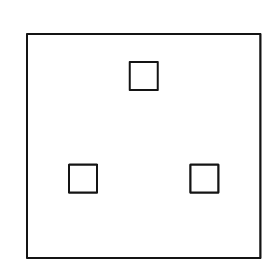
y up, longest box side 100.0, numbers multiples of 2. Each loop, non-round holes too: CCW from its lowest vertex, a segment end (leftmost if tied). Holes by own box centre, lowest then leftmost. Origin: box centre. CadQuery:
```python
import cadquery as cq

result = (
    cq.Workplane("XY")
    .moveTo(-50.0, -48.0)
    .lineTo(50.0, -48.0)
    .lineTo(50.0, 48.0)
    .lineTo(-50.0, 48.0)
    .close()
    .moveTo(-32.0, -20.0)
    .lineTo(-20.0, -20.0)
    .lineTo(-20.0, -8.0)
    .lineTo(-32.0, -8.0)
    .close()
    .moveTo(20.0, -20.0)
    .lineTo(32.0, -20.0)
    .lineTo(32.0, -8.0)
    .lineTo(20.0, -8.0)
    .close()
    .moveTo(-6.0, 24.0)
    .lineTo(6.0, 24.0)
    .lineTo(6.0, 36.0)
    .lineTo(-6.0, 36.0)
    .close()
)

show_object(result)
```